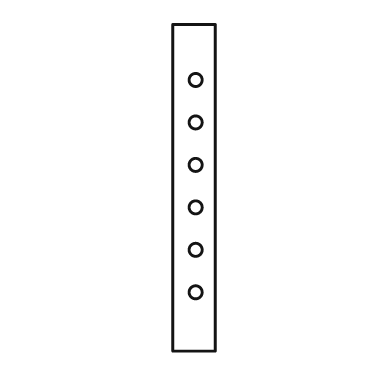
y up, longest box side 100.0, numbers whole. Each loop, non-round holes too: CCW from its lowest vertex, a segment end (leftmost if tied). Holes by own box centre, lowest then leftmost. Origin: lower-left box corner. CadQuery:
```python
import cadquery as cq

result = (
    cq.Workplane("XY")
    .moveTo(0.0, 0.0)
    .lineTo(13.0, 0.0)
    .lineTo(13.0, 100.0)
    .lineTo(0.0, 100.0)
    .close()
    .moveTo(7.0, 18.0)
    .circle(2.0)
    .moveTo(7.0, 31.0)
    .circle(2.0)
    .moveTo(7.0, 44.0)
    .circle(2.0)
    .moveTo(7.0, 57.0)
    .circle(2.0)
    .moveTo(7.0, 70.0)
    .circle(2.0)
    .moveTo(7.0, 83.0)
    .circle(2.0)
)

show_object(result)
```